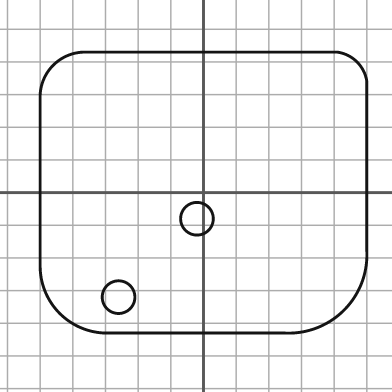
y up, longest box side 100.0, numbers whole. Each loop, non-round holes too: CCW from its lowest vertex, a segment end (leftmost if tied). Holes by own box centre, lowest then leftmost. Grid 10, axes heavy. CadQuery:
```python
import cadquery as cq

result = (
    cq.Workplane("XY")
    .moveTo(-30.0, -43.0)
    .lineTo(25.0, -43.0)
    .threePointArc((43.0, -36.0), (50.0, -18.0))
    .lineTo(50.0, 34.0)
    .threePointArc((47.0, 40.0), (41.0, 43.0))
    .lineTo(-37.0, 43.0)
    .threePointArc((-46.0, 39.0), (-50.0, 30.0))
    .lineTo(-50.0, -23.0)
    .threePointArc((-44.0, -37.0), (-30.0, -43.0))
    .close()
    .moveTo(-26.0, -32.0)
    .circle(5.0)
    .moveTo(-2.0, -8.0)
    .circle(5.0)
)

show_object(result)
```